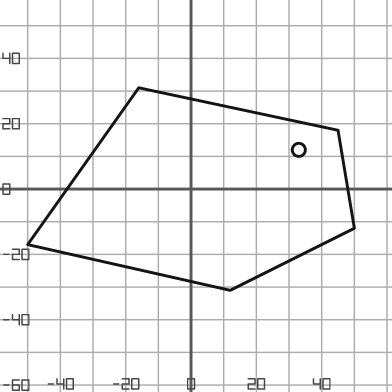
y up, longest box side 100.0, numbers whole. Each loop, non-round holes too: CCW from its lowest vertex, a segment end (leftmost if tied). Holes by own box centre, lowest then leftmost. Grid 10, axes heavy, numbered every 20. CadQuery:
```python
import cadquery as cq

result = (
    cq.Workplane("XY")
    .moveTo(12.0, -31.0)
    .lineTo(50.0, -12.0)
    .lineTo(45.0, 18.0)
    .lineTo(-16.0, 31.0)
    .lineTo(-50.0, -17.0)
    .close()
    .moveTo(33.0, 12.0)
    .circle(2.0)
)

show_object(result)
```